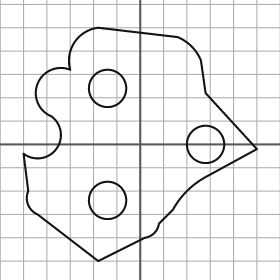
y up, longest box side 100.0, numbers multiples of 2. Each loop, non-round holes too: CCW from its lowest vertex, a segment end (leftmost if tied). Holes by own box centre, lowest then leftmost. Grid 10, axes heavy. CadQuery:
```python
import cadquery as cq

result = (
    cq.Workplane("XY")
    .moveTo(-18.0, -50.0)
    .lineTo(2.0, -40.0)
    .threePointArc((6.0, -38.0), (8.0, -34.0))
    .lineTo(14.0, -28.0)
    .threePointArc((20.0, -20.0), (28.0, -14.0))
    .lineTo(50.0, -2.0)
    .lineTo(28.0, 22.0)
    .lineTo(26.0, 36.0)
    .threePointArc((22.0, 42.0), (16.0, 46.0))
    .lineTo(-18.0, 50.0)
    .threePointArc((-28.0, 44.0), (-30.0, 32.0))
    .threePointArc((-44.0, 26.0), (-38.0, 12.0))
    .threePointArc((-36.0, -2.0), (-50.0, -4.0))
    .lineTo(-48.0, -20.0)
    .threePointArc((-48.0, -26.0), (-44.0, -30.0))
    .close()
    .moveTo(-14.0, -24.0)
    .circle(8.0)
    .moveTo(28.0, 0.0)
    .circle(8.0)
    .moveTo(-14.0, 24.0)
    .circle(8.0)
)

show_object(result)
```